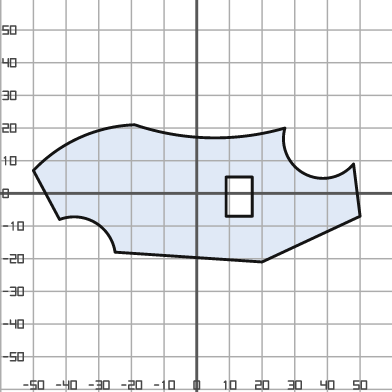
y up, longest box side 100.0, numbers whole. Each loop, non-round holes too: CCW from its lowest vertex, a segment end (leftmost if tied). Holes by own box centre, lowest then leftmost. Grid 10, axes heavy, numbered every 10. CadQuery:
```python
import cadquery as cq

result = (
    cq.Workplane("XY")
    .moveTo(20.0, -21.0)
    .lineTo(50.0, -7.0)
    .lineTo(48.0, 9.0)
    .threePointArc((33.0, 6.0), (27.0, 20.0))
    .threePointArc((4.0, 17.0), (-19.0, 21.0))
    .threePointArc((-36.0, 17.0), (-50.0, 7.0))
    .lineTo(-42.0, -8.0)
    .threePointArc((-31.0, -9.0), (-25.0, -18.0))
    .close()
    .moveTo(9.0, -7.0)
    .lineTo(17.0, -7.0)
    .lineTo(17.0, 5.0)
    .lineTo(9.0, 5.0)
    .close()
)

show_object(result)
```